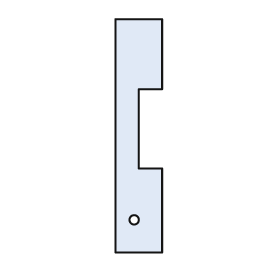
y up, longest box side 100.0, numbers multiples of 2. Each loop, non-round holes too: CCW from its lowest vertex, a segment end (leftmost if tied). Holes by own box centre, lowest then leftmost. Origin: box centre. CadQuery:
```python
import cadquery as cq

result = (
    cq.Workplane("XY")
    .moveTo(-10.0, -50.0)
    .lineTo(10.0, -50.0)
    .lineTo(10.0, -14.0)
    .lineTo(0.0, -14.0)
    .lineTo(0.0, 20.0)
    .lineTo(10.0, 20.0)
    .lineTo(10.0, 50.0)
    .lineTo(-10.0, 50.0)
    .close()
    .moveTo(-2.0, -36.0)
    .circle(2.0)
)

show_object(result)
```